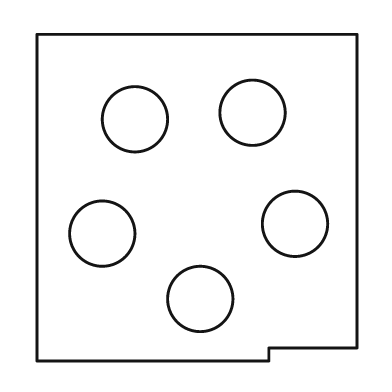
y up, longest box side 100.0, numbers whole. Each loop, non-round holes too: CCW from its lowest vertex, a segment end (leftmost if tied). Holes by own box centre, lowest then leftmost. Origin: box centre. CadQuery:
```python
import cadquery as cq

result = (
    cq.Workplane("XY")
    .moveTo(-49.0, -50.0)
    .lineTo(22.0, -50.0)
    .lineTo(22.0, -46.0)
    .lineTo(49.0, -46.0)
    .lineTo(49.0, 50.0)
    .lineTo(-49.0, 50.0)
    .close()
    .moveTo(1.0, -31.0)
    .circle(10.0)
    .moveTo(-29.0, -11.0)
    .circle(10.0)
    .moveTo(30.0, -8.0)
    .circle(10.0)
    .moveTo(-19.0, 24.0)
    .circle(10.0)
    .moveTo(17.0, 26.0)
    .circle(10.0)
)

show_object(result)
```